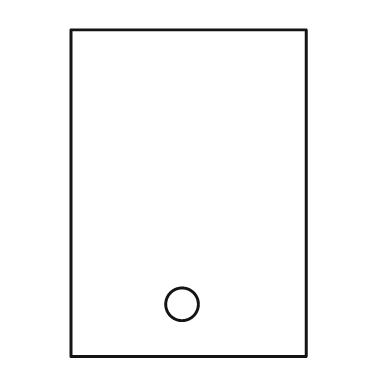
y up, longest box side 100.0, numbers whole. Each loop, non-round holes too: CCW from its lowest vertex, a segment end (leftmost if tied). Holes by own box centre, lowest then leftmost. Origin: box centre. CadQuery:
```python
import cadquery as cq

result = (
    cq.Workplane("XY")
    .moveTo(-36.0, -50.0)
    .lineTo(36.0, -50.0)
    .lineTo(36.0, 50.0)
    .lineTo(-36.0, 50.0)
    .close()
    .moveTo(-2.0, -34.0)
    .circle(5.0)
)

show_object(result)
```